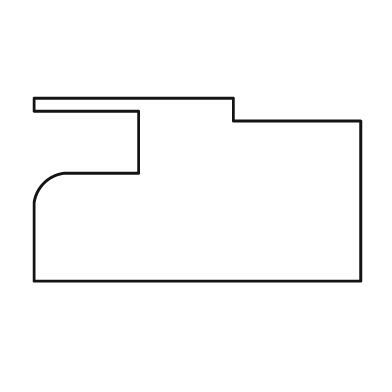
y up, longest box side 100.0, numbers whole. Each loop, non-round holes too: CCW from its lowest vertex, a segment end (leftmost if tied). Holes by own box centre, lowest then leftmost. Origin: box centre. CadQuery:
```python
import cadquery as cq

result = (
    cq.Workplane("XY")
    .moveTo(-50.0, -28.0)
    .lineTo(50.0, -28.0)
    .lineTo(50.0, 21.0)
    .lineTo(11.0, 21.0)
    .lineTo(11.0, 28.0)
    .lineTo(-50.0, 28.0)
    .lineTo(-50.0, 24.0)
    .lineTo(-18.0, 24.0)
    .lineTo(-18.0, 5.0)
    .lineTo(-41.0, 5.0)
    .threePointArc((-47.0, 2.0), (-50.0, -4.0))
    .close()
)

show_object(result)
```